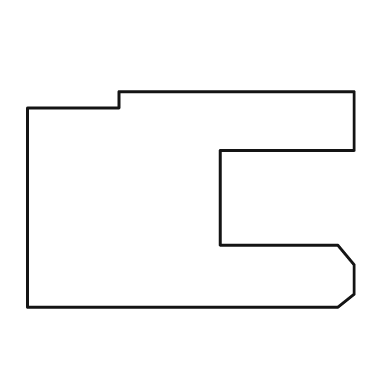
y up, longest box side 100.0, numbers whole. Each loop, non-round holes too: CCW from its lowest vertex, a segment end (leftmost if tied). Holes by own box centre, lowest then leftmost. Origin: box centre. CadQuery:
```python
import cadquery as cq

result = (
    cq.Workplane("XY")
    .moveTo(-50.0, -33.0)
    .lineTo(45.0, -33.0)
    .lineTo(50.0, -29.0)
    .lineTo(50.0, -20.0)
    .lineTo(45.0, -14.0)
    .lineTo(9.0, -14.0)
    .lineTo(9.0, 15.0)
    .lineTo(50.0, 15.0)
    .lineTo(50.0, 33.0)
    .lineTo(-22.0, 33.0)
    .lineTo(-22.0, 28.0)
    .lineTo(-50.0, 28.0)
    .close()
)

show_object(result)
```